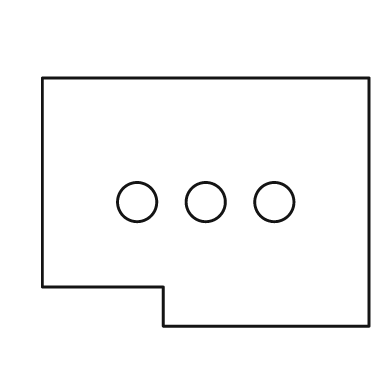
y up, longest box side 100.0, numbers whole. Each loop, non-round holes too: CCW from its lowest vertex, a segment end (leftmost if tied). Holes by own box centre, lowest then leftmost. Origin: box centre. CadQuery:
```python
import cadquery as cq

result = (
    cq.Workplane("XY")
    .moveTo(-13.0, -38.0)
    .lineTo(50.0, -38.0)
    .lineTo(50.0, 38.0)
    .lineTo(-50.0, 38.0)
    .lineTo(-50.0, -26.0)
    .lineTo(-13.0, -26.0)
    .close()
    .moveTo(-21.0, 0.0)
    .circle(6.0)
    .moveTo(0.0, 0.0)
    .circle(6.0)
    .moveTo(21.0, 0.0)
    .circle(6.0)
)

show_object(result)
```